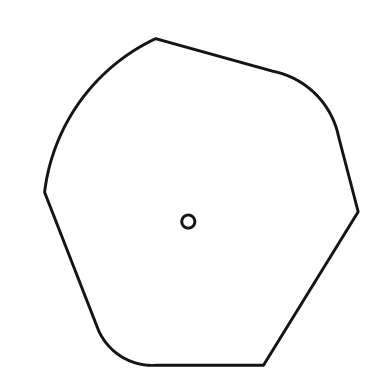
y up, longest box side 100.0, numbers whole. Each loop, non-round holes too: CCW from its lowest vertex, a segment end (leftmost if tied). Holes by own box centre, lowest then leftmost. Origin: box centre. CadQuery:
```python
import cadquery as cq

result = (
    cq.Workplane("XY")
    .moveTo(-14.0, -50.0)
    .lineTo(19.0, -50.0)
    .lineTo(48.0, -3.0)
    .lineTo(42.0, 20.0)
    .threePointArc((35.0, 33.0), (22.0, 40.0))
    .lineTo(-14.0, 50.0)
    .threePointArc((-37.0, 31.0), (-48.0, 3.0))
    .lineTo(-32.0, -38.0)
    .threePointArc((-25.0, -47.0), (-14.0, -50.0))
    .close()
    .moveTo(-4.0, -6.0)
    .circle(2.0)
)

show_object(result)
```